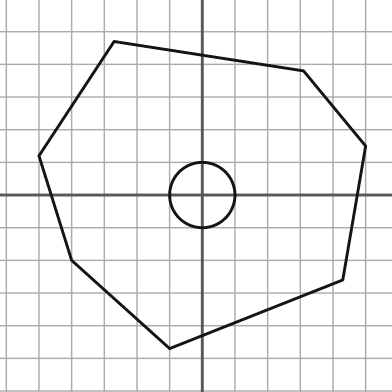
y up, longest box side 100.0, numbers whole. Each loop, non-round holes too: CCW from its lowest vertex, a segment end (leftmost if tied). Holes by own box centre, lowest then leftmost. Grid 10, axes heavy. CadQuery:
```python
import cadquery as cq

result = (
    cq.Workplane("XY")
    .moveTo(-10.0, -47.0)
    .lineTo(43.0, -26.0)
    .lineTo(50.0, 15.0)
    .lineTo(31.0, 38.0)
    .lineTo(-27.0, 47.0)
    .lineTo(-50.0, 12.0)
    .lineTo(-40.0, -20.0)
    .close()
    .moveTo(0.0, 0.0)
    .circle(10.0)
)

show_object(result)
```